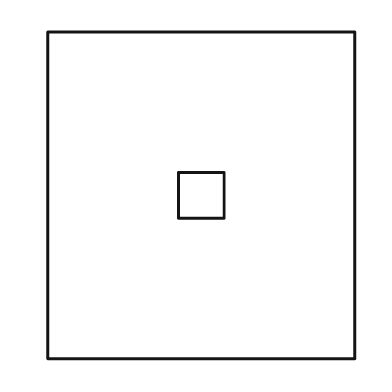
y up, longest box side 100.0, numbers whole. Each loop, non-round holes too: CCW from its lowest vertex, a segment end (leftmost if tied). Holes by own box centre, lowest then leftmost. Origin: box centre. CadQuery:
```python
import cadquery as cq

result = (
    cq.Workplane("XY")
    .moveTo(-47.0, -50.0)
    .lineTo(47.0, -50.0)
    .lineTo(47.0, 50.0)
    .lineTo(-47.0, 50.0)
    .close()
    .moveTo(-7.0, -7.0)
    .lineTo(7.0, -7.0)
    .lineTo(7.0, 7.0)
    .lineTo(-7.0, 7.0)
    .close()
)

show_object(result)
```